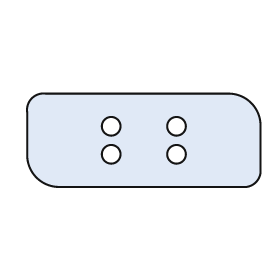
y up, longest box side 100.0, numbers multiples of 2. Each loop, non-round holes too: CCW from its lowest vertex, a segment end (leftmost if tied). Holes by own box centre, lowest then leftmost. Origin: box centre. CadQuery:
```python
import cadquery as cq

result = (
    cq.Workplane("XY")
    .moveTo(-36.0, -20.0)
    .lineTo(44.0, -20.0)
    .threePointArc((48.0, -18.0), (50.0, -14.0))
    .lineTo(50.0, 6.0)
    .threePointArc((46.0, 16.0), (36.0, 20.0))
    .lineTo(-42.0, 20.0)
    .threePointArc((-48.0, 18.0), (-50.0, 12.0))
    .lineTo(-50.0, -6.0)
    .threePointArc((-46.0, -16.0), (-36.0, -20.0))
    .close()
    .moveTo(-14.0, -6.0)
    .circle(4.0)
    .moveTo(14.0, -6.0)
    .circle(4.0)
    .moveTo(-14.0, 6.0)
    .circle(4.0)
    .moveTo(14.0, 6.0)
    .circle(4.0)
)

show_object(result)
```